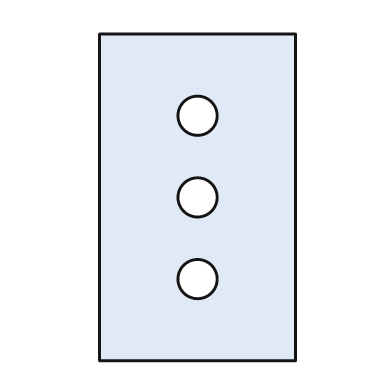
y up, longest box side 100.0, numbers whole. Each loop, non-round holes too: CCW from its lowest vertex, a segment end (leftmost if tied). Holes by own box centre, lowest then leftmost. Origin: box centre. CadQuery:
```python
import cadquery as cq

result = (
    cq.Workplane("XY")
    .moveTo(-30.0, -50.0)
    .lineTo(30.0, -50.0)
    .lineTo(30.0, 50.0)
    .lineTo(-30.0, 50.0)
    .close()
    .moveTo(0.0, -25.0)
    .circle(6.0)
    .moveTo(0.0, 0.0)
    .circle(6.0)
    .moveTo(0.0, 25.0)
    .circle(6.0)
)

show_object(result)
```